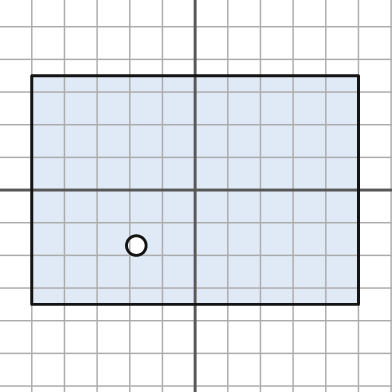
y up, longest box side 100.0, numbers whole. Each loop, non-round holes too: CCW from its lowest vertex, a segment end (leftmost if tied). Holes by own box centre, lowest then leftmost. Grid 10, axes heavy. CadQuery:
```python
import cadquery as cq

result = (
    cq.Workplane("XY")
    .moveTo(-50.0, -35.0)
    .lineTo(50.0, -35.0)
    .lineTo(50.0, 35.0)
    .lineTo(-50.0, 35.0)
    .close()
    .moveTo(-18.0, -17.0)
    .circle(3.0)
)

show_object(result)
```